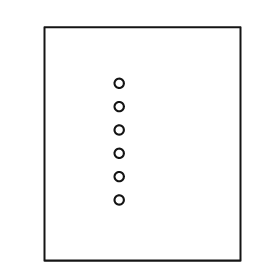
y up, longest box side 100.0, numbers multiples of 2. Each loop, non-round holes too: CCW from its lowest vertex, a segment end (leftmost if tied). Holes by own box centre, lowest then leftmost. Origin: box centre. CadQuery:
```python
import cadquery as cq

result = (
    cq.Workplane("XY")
    .moveTo(-42.0, -50.0)
    .lineTo(42.0, -50.0)
    .lineTo(42.0, 50.0)
    .lineTo(-42.0, 50.0)
    .close()
    .moveTo(-10.0, -24.0)
    .circle(2.0)
    .moveTo(-10.0, -14.0)
    .circle(2.0)
    .moveTo(-10.0, -4.0)
    .circle(2.0)
    .moveTo(-10.0, 6.0)
    .circle(2.0)
    .moveTo(-10.0, 16.0)
    .circle(2.0)
    .moveTo(-10.0, 26.0)
    .circle(2.0)
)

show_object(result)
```